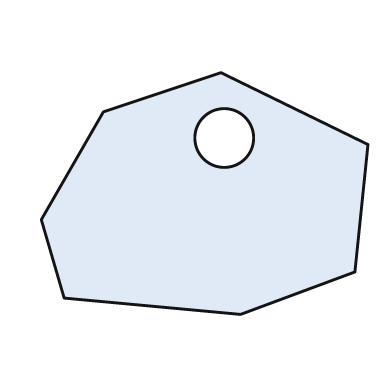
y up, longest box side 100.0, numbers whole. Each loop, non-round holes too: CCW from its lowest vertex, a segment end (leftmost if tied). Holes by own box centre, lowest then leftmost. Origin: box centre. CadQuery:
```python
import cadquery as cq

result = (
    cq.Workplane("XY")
    .moveTo(11.0, -37.0)
    .lineTo(46.0, -24.0)
    .lineTo(50.0, 15.0)
    .lineTo(5.0, 37.0)
    .lineTo(-31.0, 25.0)
    .lineTo(-50.0, -8.0)
    .lineTo(-43.0, -32.0)
    .close()
    .moveTo(6.0, 17.0)
    .circle(9.0)
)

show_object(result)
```